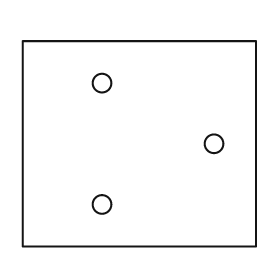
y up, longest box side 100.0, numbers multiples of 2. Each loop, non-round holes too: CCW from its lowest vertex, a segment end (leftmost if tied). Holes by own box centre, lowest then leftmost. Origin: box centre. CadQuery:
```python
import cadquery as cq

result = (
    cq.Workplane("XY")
    .moveTo(-50.0, -44.0)
    .lineTo(50.0, -44.0)
    .lineTo(50.0, 44.0)
    .lineTo(-50.0, 44.0)
    .close()
    .moveTo(-16.0, -26.0)
    .circle(4.0)
    .moveTo(32.0, 0.0)
    .circle(4.0)
    .moveTo(-16.0, 26.0)
    .circle(4.0)
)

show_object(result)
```